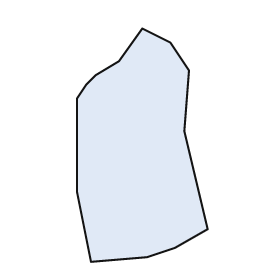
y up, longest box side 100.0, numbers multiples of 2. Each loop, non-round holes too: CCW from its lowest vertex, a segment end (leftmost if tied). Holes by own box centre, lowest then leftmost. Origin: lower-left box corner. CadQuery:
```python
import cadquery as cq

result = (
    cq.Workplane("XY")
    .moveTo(6.0, 0.0)
    .lineTo(30.0, 2.0)
    .lineTo(42.0, 6.0)
    .lineTo(56.0, 14.0)
    .lineTo(46.0, 56.0)
    .lineTo(48.0, 82.0)
    .lineTo(40.0, 94.0)
    .lineTo(28.0, 100.0)
    .lineTo(18.0, 86.0)
    .lineTo(8.0, 80.0)
    .lineTo(4.0, 76.0)
    .lineTo(0.0, 70.0)
    .lineTo(0.0, 30.0)
    .close()
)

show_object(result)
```